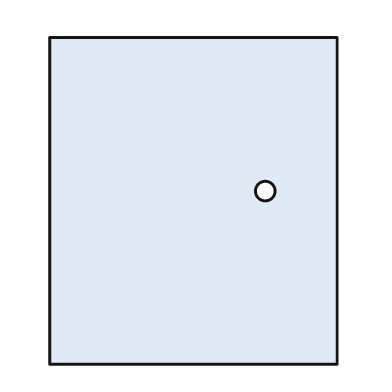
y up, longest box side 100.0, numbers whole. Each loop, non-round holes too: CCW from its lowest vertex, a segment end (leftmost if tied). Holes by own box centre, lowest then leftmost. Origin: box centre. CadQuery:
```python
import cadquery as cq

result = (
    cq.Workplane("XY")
    .moveTo(-44.0, -50.0)
    .lineTo(44.0, -50.0)
    .lineTo(44.0, 50.0)
    .lineTo(-44.0, 50.0)
    .close()
    .moveTo(22.0, 3.0)
    .circle(3.0)
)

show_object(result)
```